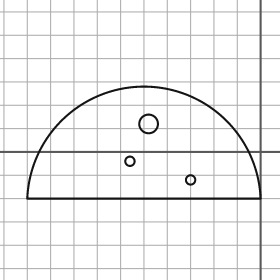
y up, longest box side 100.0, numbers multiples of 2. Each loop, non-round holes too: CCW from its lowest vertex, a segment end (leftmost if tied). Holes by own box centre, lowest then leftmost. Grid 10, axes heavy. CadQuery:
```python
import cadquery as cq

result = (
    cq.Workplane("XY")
    .moveTo(-100.0, -20.0)
    .lineTo(0.0, -20.0)
    .threePointArc((-50.0, 28.0), (-100.0, -20.0))
    .close()
    .moveTo(-30.0, -12.0)
    .circle(2.0)
    .moveTo(-56.0, -4.0)
    .circle(2.0)
    .moveTo(-48.0, 12.0)
    .circle(4.0)
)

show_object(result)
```